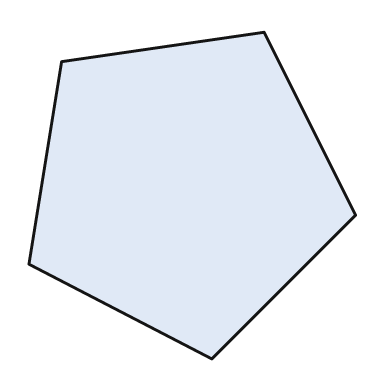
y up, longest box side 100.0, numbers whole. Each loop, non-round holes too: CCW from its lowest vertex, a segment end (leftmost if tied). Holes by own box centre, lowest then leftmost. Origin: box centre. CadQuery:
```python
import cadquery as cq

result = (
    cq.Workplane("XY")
    .moveTo(6.0, -50.0)
    .lineTo(50.0, -6.0)
    .lineTo(22.0, 50.0)
    .lineTo(-40.0, 41.0)
    .lineTo(-50.0, -21.0)
    .close()
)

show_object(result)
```